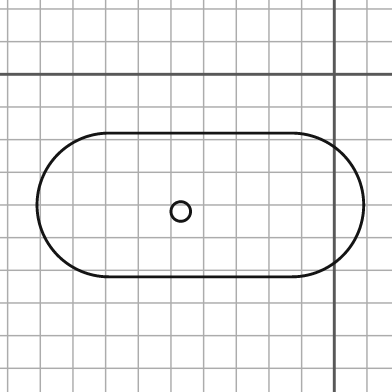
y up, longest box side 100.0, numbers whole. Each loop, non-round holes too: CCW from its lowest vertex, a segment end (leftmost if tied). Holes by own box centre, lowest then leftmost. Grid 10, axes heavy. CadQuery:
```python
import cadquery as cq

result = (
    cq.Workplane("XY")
    .moveTo(-69.0, -62.0)
    .lineTo(-13.0, -62.0)
    .threePointArc((9.0, -40.0), (-13.0, -18.0))
    .lineTo(-69.0, -18.0)
    .threePointArc((-91.0, -40.0), (-69.0, -62.0))
    .close()
    .moveTo(-47.0, -42.0)
    .circle(3.0)
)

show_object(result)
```